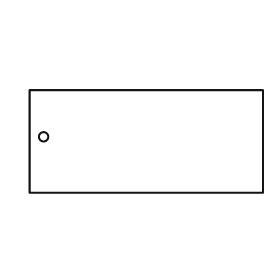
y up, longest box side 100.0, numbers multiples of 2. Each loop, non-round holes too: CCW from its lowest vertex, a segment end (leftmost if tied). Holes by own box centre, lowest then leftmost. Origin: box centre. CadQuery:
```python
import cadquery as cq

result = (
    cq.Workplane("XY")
    .moveTo(-50.0, -22.0)
    .lineTo(50.0, -22.0)
    .lineTo(50.0, 22.0)
    .lineTo(-50.0, 22.0)
    .close()
    .moveTo(-44.0, 2.0)
    .circle(2.0)
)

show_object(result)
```